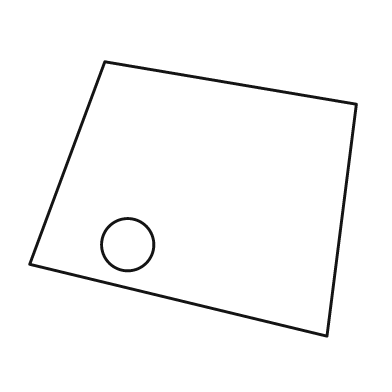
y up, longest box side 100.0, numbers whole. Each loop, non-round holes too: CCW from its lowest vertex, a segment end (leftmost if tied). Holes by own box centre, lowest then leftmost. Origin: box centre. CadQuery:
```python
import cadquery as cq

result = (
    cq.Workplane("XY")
    .moveTo(41.0, -42.0)
    .lineTo(50.0, 29.0)
    .lineTo(-27.0, 42.0)
    .lineTo(-50.0, -20.0)
    .close()
    .moveTo(-20.0, -14.0)
    .circle(8.0)
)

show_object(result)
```